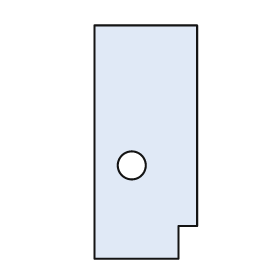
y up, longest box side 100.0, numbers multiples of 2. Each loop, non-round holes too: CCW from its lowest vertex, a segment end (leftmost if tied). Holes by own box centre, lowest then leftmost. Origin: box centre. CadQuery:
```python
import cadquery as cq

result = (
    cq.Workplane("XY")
    .moveTo(-22.0, -50.0)
    .lineTo(14.0, -50.0)
    .lineTo(14.0, -36.0)
    .lineTo(22.0, -36.0)
    .lineTo(22.0, 50.0)
    .lineTo(-22.0, 50.0)
    .close()
    .moveTo(-6.0, -10.0)
    .circle(6.0)
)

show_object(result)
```